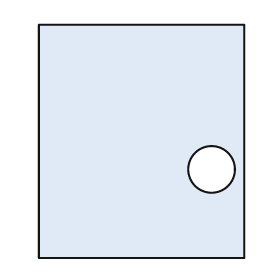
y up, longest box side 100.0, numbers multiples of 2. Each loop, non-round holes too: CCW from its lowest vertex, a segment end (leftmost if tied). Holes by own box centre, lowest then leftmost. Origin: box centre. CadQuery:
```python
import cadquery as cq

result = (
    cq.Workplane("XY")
    .moveTo(-44.0, -50.0)
    .lineTo(44.0, -50.0)
    .lineTo(44.0, 50.0)
    .lineTo(-44.0, 50.0)
    .close()
    .moveTo(30.0, -12.0)
    .circle(10.0)
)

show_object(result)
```